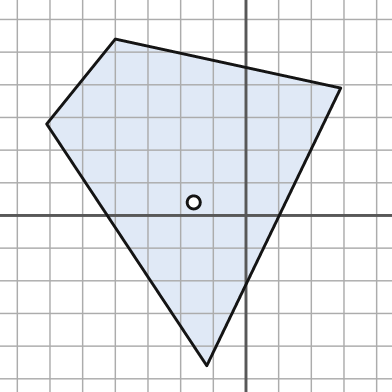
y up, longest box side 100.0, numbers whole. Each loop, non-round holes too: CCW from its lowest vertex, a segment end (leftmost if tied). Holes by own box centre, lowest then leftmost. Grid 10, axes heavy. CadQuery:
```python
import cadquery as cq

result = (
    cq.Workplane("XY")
    .moveTo(-12.0, -46.0)
    .lineTo(29.0, 39.0)
    .lineTo(-40.0, 54.0)
    .lineTo(-61.0, 28.0)
    .close()
    .moveTo(-16.0, 4.0)
    .circle(2.0)
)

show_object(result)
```